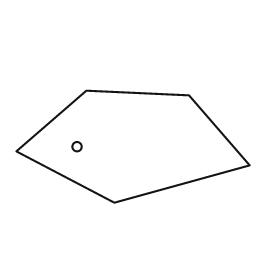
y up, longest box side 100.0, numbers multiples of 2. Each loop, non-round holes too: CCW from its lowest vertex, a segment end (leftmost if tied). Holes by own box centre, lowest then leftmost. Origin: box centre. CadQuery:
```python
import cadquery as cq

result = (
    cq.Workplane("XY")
    .moveTo(-8.0, -24.0)
    .lineTo(50.0, -8.0)
    .lineTo(24.0, 22.0)
    .lineTo(-20.0, 24.0)
    .lineTo(-50.0, -2.0)
    .close()
    .moveTo(-24.0, 0.0)
    .circle(2.0)
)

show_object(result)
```